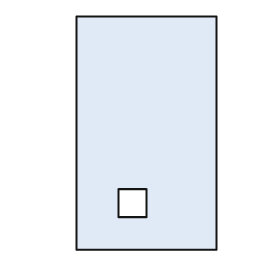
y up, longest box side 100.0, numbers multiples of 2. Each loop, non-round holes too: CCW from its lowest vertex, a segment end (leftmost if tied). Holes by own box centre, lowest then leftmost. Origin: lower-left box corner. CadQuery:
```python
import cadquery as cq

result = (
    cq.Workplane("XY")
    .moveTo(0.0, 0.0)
    .lineTo(60.0, 0.0)
    .lineTo(60.0, 100.0)
    .lineTo(0.0, 100.0)
    .close()
    .moveTo(18.0, 14.0)
    .lineTo(30.0, 14.0)
    .lineTo(30.0, 26.0)
    .lineTo(18.0, 26.0)
    .close()
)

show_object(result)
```